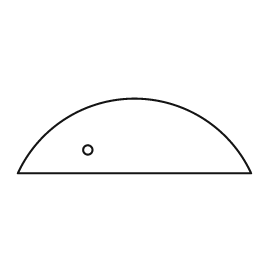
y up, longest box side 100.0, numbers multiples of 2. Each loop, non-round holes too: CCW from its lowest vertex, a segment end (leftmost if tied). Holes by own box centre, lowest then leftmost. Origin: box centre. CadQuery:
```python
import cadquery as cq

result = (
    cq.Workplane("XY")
    .moveTo(-50.0, -16.0)
    .lineTo(50.0, -16.0)
    .threePointArc((0.0, 16.0), (-50.0, -16.0))
    .close()
    .moveTo(-20.0, -6.0)
    .circle(2.0)
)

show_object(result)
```